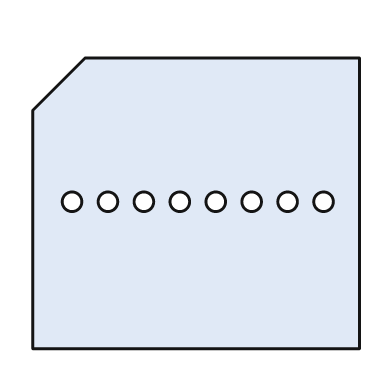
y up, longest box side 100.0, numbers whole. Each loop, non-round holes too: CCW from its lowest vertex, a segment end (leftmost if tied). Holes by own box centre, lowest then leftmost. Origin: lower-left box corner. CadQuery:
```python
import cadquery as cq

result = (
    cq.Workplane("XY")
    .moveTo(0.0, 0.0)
    .lineTo(100.0, 0.0)
    .lineTo(100.0, 89.0)
    .lineTo(16.0, 89.0)
    .lineTo(0.0, 73.0)
    .close()
    .moveTo(12.0, 45.0)
    .circle(3.0)
    .moveTo(23.0, 45.0)
    .circle(3.0)
    .moveTo(34.0, 45.0)
    .circle(3.0)
    .moveTo(45.0, 45.0)
    .circle(3.0)
    .moveTo(56.0, 45.0)
    .circle(3.0)
    .moveTo(67.0, 45.0)
    .circle(3.0)
    .moveTo(78.0, 45.0)
    .circle(3.0)
    .moveTo(89.0, 45.0)
    .circle(3.0)
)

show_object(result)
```